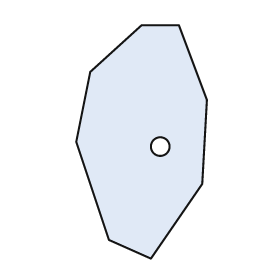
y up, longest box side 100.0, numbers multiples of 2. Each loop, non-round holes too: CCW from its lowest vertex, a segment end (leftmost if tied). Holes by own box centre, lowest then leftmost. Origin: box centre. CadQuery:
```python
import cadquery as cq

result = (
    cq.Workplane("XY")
    .moveTo(4.0, -50.0)
    .lineTo(26.0, -18.0)
    .lineTo(28.0, 18.0)
    .lineTo(16.0, 50.0)
    .lineTo(0.0, 50.0)
    .lineTo(-22.0, 30.0)
    .lineTo(-28.0, 0.0)
    .lineTo(-14.0, -42.0)
    .close()
    .moveTo(8.0, -2.0)
    .circle(4.0)
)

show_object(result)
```